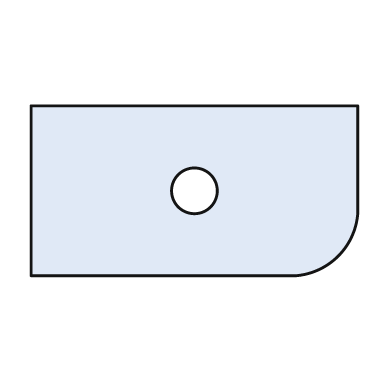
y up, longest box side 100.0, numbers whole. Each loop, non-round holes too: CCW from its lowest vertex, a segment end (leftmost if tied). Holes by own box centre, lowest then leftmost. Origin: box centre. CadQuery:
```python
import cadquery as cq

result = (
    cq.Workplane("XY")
    .moveTo(-50.0, -26.0)
    .lineTo(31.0, -26.0)
    .threePointArc((44.0, -20.0), (50.0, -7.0))
    .lineTo(50.0, 26.0)
    .lineTo(-50.0, 26.0)
    .close()
    .moveTo(0.0, 0.0)
    .circle(7.0)
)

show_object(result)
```